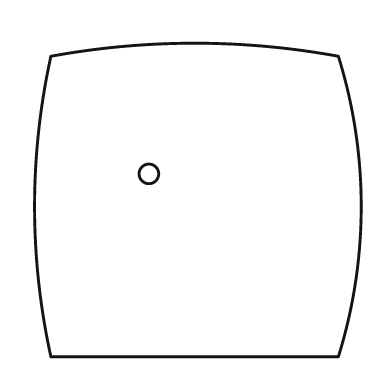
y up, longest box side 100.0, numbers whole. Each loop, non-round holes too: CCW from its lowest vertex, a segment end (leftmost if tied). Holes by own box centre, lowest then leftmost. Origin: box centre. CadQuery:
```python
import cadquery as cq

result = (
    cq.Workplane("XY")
    .moveTo(-45.0, -48.0)
    .lineTo(43.0, -48.0)
    .threePointArc((50.0, -2.0), (43.0, 44.0))
    .threePointArc((-1.0, 48.0), (-45.0, 44.0))
    .threePointArc((-50.0, -2.0), (-45.0, -48.0))
    .close()
    .moveTo(-15.0, 8.0)
    .circle(3.0)
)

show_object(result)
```